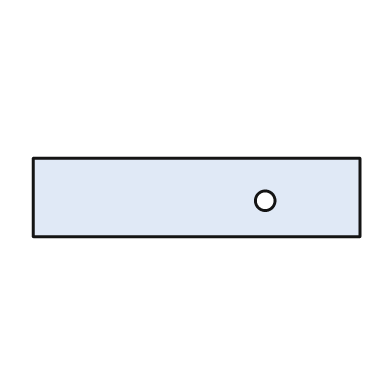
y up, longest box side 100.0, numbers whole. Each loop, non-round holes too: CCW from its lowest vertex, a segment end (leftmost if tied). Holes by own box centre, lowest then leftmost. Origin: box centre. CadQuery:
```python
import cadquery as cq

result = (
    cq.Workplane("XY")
    .moveTo(-50.0, -12.0)
    .lineTo(50.0, -12.0)
    .lineTo(50.0, 12.0)
    .lineTo(-50.0, 12.0)
    .close()
    .moveTo(21.0, -1.0)
    .circle(3.0)
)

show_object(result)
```